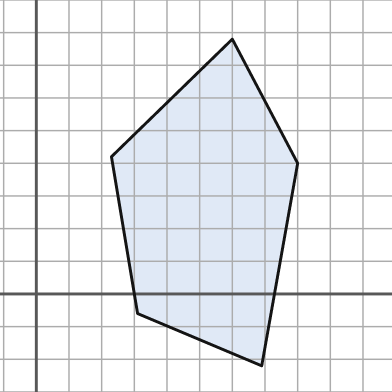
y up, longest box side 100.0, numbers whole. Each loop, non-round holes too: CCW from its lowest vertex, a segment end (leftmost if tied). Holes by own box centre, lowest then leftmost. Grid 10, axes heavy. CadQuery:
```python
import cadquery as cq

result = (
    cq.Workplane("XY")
    .moveTo(69.0, -22.0)
    .lineTo(80.0, 40.0)
    .lineTo(60.0, 78.0)
    .lineTo(23.0, 42.0)
    .lineTo(31.0, -6.0)
    .close()
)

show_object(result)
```